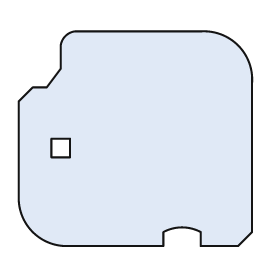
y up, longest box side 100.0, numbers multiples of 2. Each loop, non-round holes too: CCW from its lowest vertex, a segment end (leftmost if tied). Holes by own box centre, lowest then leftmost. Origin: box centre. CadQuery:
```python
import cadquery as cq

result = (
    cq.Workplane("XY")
    .moveTo(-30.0, -46.0)
    .lineTo(12.0, -46.0)
    .lineTo(12.0, -40.0)
    .threePointArc((20.0, -38.0), (28.0, -40.0))
    .lineTo(28.0, -46.0)
    .lineTo(44.0, -46.0)
    .lineTo(50.0, -40.0)
    .lineTo(50.0, 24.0)
    .threePointArc((44.0, 40.0), (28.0, 46.0))
    .lineTo(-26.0, 46.0)
    .threePointArc((-30.0, 44.0), (-32.0, 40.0))
    .lineTo(-32.0, 30.0)
    .lineTo(-38.0, 22.0)
    .lineTo(-44.0, 22.0)
    .lineTo(-50.0, 16.0)
    .lineTo(-50.0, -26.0)
    .threePointArc((-44.0, -40.0), (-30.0, -46.0))
    .close()
    .moveTo(-36.0, -8.0)
    .lineTo(-28.0, -8.0)
    .lineTo(-28.0, 0.0)
    .lineTo(-36.0, 0.0)
    .close()
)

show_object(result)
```